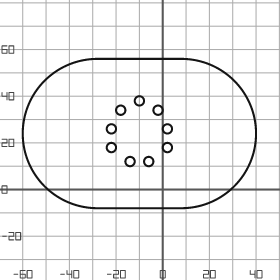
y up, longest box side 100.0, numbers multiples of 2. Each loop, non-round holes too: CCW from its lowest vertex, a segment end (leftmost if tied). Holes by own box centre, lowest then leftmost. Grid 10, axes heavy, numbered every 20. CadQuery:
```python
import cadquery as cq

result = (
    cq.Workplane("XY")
    .moveTo(-28.0, -8.0)
    .lineTo(8.0, -8.0)
    .threePointArc((40.0, 24.0), (8.0, 56.0))
    .lineTo(-28.0, 56.0)
    .threePointArc((-60.0, 24.0), (-28.0, -8.0))
    .close()
    .moveTo(-14.0, 12.0)
    .circle(2.0)
    .moveTo(-6.0, 12.0)
    .circle(2.0)
    .moveTo(-22.0, 18.0)
    .circle(2.0)
    .moveTo(2.0, 18.0)
    .circle(2.0)
    .moveTo(-22.0, 26.0)
    .circle(2.0)
    .moveTo(2.0, 26.0)
    .circle(2.0)
    .moveTo(-18.0, 34.0)
    .circle(2.0)
    .moveTo(-2.0, 34.0)
    .circle(2.0)
    .moveTo(-10.0, 38.0)
    .circle(2.0)
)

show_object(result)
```